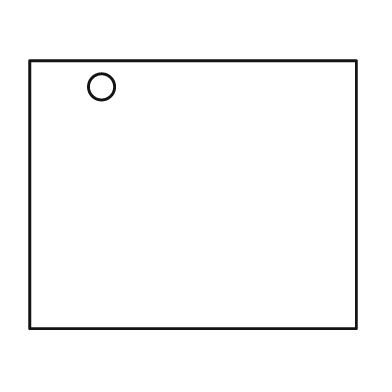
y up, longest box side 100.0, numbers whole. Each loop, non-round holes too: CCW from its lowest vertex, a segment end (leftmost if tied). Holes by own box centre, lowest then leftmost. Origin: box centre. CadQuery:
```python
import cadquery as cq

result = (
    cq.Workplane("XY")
    .moveTo(-50.0, -41.0)
    .lineTo(50.0, -41.0)
    .lineTo(50.0, 41.0)
    .lineTo(-50.0, 41.0)
    .close()
    .moveTo(-28.0, 33.0)
    .circle(4.0)
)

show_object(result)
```